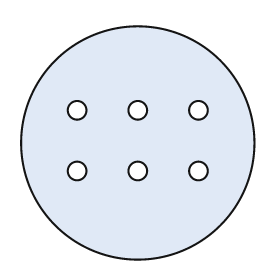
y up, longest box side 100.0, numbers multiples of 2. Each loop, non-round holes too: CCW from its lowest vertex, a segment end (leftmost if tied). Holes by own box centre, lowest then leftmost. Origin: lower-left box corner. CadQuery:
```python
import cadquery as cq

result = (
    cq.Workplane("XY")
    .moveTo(50.0, 50.0)
    .circle(50.0)
    .moveTo(24.0, 38.0)
    .circle(4.0)
    .moveTo(50.0, 38.0)
    .circle(4.0)
    .moveTo(76.0, 38.0)
    .circle(4.0)
    .moveTo(24.0, 64.0)
    .circle(4.0)
    .moveTo(50.0, 64.0)
    .circle(4.0)
    .moveTo(76.0, 64.0)
    .circle(4.0)
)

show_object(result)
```